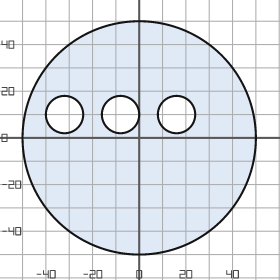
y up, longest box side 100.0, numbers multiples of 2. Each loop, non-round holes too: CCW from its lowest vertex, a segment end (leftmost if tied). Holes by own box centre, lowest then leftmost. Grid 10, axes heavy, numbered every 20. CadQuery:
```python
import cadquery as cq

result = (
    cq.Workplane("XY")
    .moveTo(0.0, 0.0)
    .circle(50.0)
    .moveTo(-32.0, 10.0)
    .circle(8.0)
    .moveTo(-8.0, 10.0)
    .circle(8.0)
    .moveTo(16.0, 10.0)
    .circle(8.0)
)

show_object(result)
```